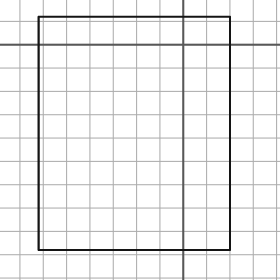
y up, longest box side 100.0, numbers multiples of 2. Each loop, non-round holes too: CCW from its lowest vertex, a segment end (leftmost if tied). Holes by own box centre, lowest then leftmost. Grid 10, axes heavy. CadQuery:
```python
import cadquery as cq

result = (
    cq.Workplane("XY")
    .moveTo(-62.0, -88.0)
    .lineTo(20.0, -88.0)
    .lineTo(20.0, 12.0)
    .lineTo(-62.0, 12.0)
    .close()
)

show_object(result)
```